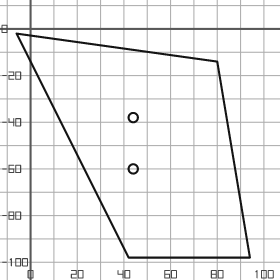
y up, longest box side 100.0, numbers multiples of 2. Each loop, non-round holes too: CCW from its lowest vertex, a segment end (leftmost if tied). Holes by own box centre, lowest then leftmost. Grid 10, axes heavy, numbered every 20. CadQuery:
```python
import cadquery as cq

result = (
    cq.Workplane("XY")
    .moveTo(42.0, -98.0)
    .lineTo(94.0, -98.0)
    .lineTo(80.0, -14.0)
    .lineTo(-6.0, -2.0)
    .close()
    .moveTo(44.0, -60.0)
    .circle(2.0)
    .moveTo(44.0, -38.0)
    .circle(2.0)
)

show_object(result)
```